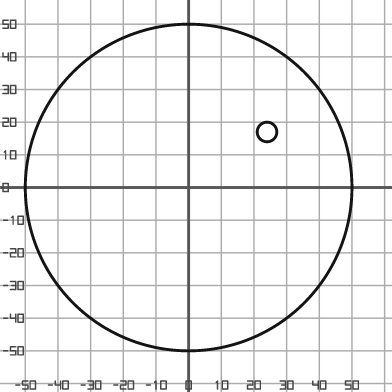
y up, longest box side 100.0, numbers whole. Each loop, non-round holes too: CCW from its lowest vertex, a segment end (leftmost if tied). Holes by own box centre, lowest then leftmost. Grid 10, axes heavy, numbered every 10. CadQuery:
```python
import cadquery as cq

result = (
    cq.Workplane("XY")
    .moveTo(0.0, 0.0)
    .circle(50.0)
    .moveTo(24.0, 17.0)
    .circle(3.0)
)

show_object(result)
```